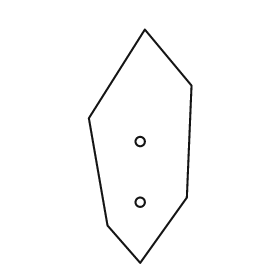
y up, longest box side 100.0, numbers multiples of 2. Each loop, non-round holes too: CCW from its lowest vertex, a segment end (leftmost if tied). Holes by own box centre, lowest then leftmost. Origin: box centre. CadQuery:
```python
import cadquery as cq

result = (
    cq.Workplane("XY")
    .moveTo(0.0, -50.0)
    .lineTo(20.0, -22.0)
    .lineTo(22.0, 26.0)
    .lineTo(2.0, 50.0)
    .lineTo(-22.0, 12.0)
    .lineTo(-14.0, -34.0)
    .close()
    .moveTo(0.0, -24.0)
    .circle(2.0)
    .moveTo(0.0, 2.0)
    .circle(2.0)
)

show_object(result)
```